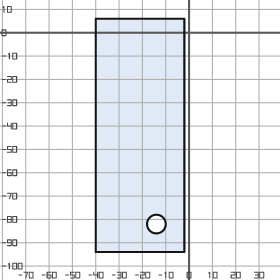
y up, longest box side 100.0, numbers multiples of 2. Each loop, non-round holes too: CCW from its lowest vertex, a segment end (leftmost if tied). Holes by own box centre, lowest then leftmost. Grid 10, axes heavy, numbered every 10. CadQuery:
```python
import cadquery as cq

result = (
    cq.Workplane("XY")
    .moveTo(-40.0, -94.0)
    .lineTo(-2.0, -94.0)
    .lineTo(-2.0, 6.0)
    .lineTo(-40.0, 6.0)
    .close()
    .moveTo(-14.0, -82.0)
    .circle(4.0)
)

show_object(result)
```